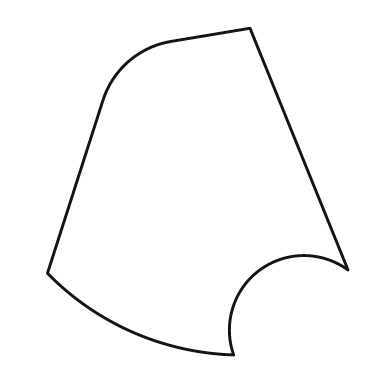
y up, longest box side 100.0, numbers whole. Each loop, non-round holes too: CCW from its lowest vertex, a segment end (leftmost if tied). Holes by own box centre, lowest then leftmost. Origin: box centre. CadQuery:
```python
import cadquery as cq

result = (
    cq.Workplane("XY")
    .moveTo(11.0, -50.0)
    .threePointArc((19.0, -24.0), (46.0, -24.0))
    .lineTo(16.0, 50.0)
    .lineTo(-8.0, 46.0)
    .threePointArc((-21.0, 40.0), (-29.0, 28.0))
    .lineTo(-46.0, -25.0)
    .threePointArc((-20.0, -43.0), (11.0, -50.0))
    .close()
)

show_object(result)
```